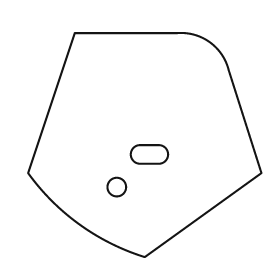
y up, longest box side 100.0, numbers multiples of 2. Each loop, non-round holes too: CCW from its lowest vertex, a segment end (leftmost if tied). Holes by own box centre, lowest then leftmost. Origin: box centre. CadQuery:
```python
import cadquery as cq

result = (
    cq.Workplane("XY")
    .moveTo(0.0, -48.0)
    .lineTo(50.0, -12.0)
    .lineTo(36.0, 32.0)
    .threePointArc((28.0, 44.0), (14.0, 48.0))
    .lineTo(-30.0, 48.0)
    .lineTo(-50.0, -12.0)
    .threePointArc((-28.0, -34.0), (0.0, -48.0))
    .close()
    .moveTo(-12.0, -18.0)
    .circle(4.0)
    .moveTo(-2.0, -8.0)
    .lineTo(6.0, -8.0)
    .threePointArc((10.0, -4.0), (6.0, 0.0))
    .lineTo(-2.0, 0.0)
    .threePointArc((-6.0, -4.0), (-2.0, -8.0))
    .close()
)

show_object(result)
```